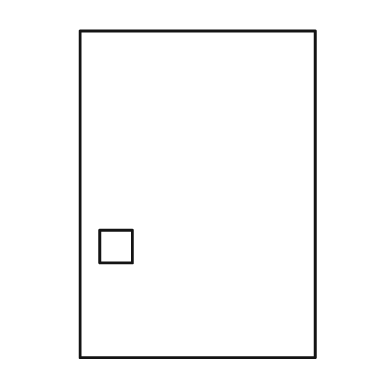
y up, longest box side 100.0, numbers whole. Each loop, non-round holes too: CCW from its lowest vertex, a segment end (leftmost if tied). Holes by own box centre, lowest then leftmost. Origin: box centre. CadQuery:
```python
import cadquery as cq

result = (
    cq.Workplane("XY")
    .moveTo(-36.0, -50.0)
    .lineTo(36.0, -50.0)
    .lineTo(36.0, 50.0)
    .lineTo(-36.0, 50.0)
    .close()
    .moveTo(-30.0, -21.0)
    .lineTo(-20.0, -21.0)
    .lineTo(-20.0, -11.0)
    .lineTo(-30.0, -11.0)
    .close()
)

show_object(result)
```